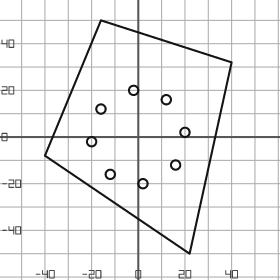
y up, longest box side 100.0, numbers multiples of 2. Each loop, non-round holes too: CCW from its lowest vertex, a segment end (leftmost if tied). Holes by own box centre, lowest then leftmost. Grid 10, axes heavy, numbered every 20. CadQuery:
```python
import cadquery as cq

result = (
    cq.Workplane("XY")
    .moveTo(22.0, -50.0)
    .lineTo(40.0, 32.0)
    .lineTo(-16.0, 50.0)
    .lineTo(-40.0, -8.0)
    .close()
    .moveTo(2.0, -20.0)
    .circle(2.0)
    .moveTo(-12.0, -16.0)
    .circle(2.0)
    .moveTo(16.0, -12.0)
    .circle(2.0)
    .moveTo(-20.0, -2.0)
    .circle(2.0)
    .moveTo(20.0, 2.0)
    .circle(2.0)
    .moveTo(-16.0, 12.0)
    .circle(2.0)
    .moveTo(12.0, 16.0)
    .circle(2.0)
    .moveTo(-2.0, 20.0)
    .circle(2.0)
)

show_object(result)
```